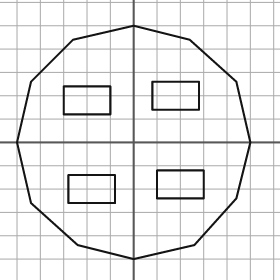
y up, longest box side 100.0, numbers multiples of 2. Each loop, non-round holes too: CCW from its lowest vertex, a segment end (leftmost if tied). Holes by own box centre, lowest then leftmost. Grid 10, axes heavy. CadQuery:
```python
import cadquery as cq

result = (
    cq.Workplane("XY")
    .moveTo(0.0, -50.0)
    .lineTo(26.0, -44.0)
    .lineTo(44.0, -24.0)
    .lineTo(50.0, 0.0)
    .lineTo(44.0, 26.0)
    .lineTo(24.0, 44.0)
    .lineTo(0.0, 50.0)
    .lineTo(-26.0, 44.0)
    .lineTo(-44.0, 26.0)
    .lineTo(-50.0, 0.0)
    .lineTo(-44.0, -26.0)
    .lineTo(-24.0, -44.0)
    .close()
    .moveTo(-28.0, -26.0)
    .lineTo(-8.0, -26.0)
    .lineTo(-8.0, -14.0)
    .lineTo(-28.0, -14.0)
    .close()
    .moveTo(10.0, -24.0)
    .lineTo(30.0, -24.0)
    .lineTo(30.0, -12.0)
    .lineTo(10.0, -12.0)
    .close()
    .moveTo(-30.0, 12.0)
    .lineTo(-10.0, 12.0)
    .lineTo(-10.0, 24.0)
    .lineTo(-30.0, 24.0)
    .close()
    .moveTo(8.0, 14.0)
    .lineTo(28.0, 14.0)
    .lineTo(28.0, 26.0)
    .lineTo(8.0, 26.0)
    .close()
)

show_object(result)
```